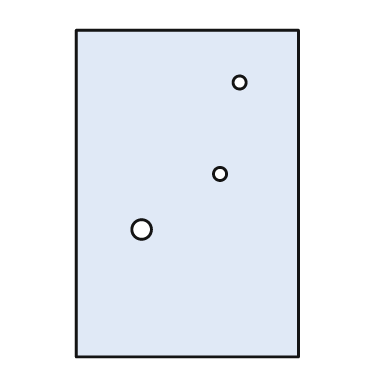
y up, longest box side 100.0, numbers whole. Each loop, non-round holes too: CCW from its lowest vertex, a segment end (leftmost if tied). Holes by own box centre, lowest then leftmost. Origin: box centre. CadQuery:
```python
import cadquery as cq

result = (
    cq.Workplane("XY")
    .moveTo(-34.0, -50.0)
    .lineTo(34.0, -50.0)
    .lineTo(34.0, 50.0)
    .lineTo(-34.0, 50.0)
    .close()
    .moveTo(-14.0, -11.0)
    .circle(3.0)
    .moveTo(10.0, 6.0)
    .circle(2.0)
    .moveTo(16.0, 34.0)
    .circle(2.0)
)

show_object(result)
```